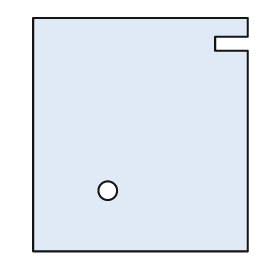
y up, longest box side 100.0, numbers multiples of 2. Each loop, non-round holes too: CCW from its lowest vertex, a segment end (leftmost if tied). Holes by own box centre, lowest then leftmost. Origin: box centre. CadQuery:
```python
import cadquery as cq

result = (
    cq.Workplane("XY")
    .moveTo(-46.0, -50.0)
    .lineTo(46.0, -50.0)
    .lineTo(46.0, 36.0)
    .lineTo(32.0, 36.0)
    .lineTo(32.0, 42.0)
    .lineTo(46.0, 42.0)
    .lineTo(46.0, 50.0)
    .lineTo(-46.0, 50.0)
    .close()
    .moveTo(-14.0, -24.0)
    .circle(4.0)
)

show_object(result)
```